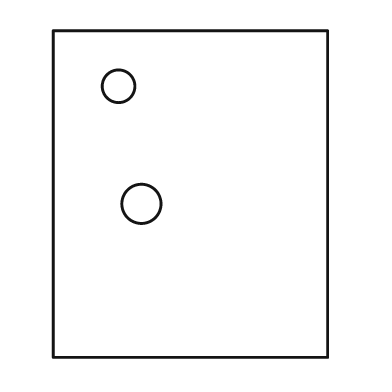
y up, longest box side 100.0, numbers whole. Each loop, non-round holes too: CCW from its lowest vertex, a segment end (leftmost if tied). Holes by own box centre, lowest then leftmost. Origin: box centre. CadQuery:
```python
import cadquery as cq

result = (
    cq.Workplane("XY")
    .moveTo(-42.0, -50.0)
    .lineTo(42.0, -50.0)
    .lineTo(42.0, 50.0)
    .lineTo(-42.0, 50.0)
    .close()
    .moveTo(-15.0, -3.0)
    .circle(6.0)
    .moveTo(-22.0, 33.0)
    .circle(5.0)
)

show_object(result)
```